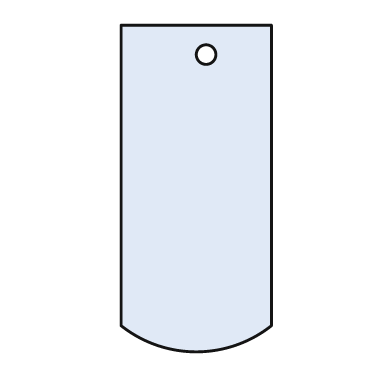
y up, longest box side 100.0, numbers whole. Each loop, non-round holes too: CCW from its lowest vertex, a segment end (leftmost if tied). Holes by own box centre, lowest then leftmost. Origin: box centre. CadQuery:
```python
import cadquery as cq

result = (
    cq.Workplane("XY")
    .moveTo(-23.0, -42.0)
    .threePointArc((0.0, -50.0), (23.0, -42.0))
    .lineTo(23.0, 50.0)
    .lineTo(-23.0, 50.0)
    .close()
    .moveTo(3.0, 41.0)
    .circle(3.0)
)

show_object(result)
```